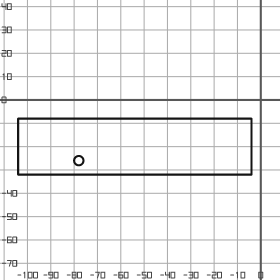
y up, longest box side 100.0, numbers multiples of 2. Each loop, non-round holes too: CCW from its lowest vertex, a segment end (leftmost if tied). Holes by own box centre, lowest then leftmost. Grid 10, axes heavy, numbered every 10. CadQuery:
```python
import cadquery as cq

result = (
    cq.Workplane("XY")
    .moveTo(-104.0, -32.0)
    .lineTo(-4.0, -32.0)
    .lineTo(-4.0, -8.0)
    .lineTo(-104.0, -8.0)
    .close()
    .moveTo(-78.0, -26.0)
    .circle(2.0)
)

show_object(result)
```